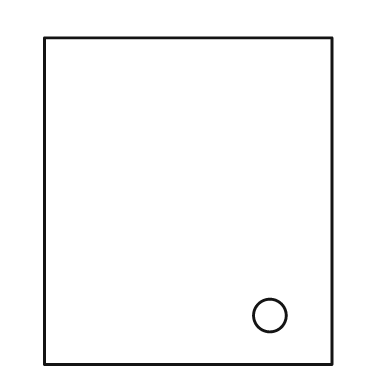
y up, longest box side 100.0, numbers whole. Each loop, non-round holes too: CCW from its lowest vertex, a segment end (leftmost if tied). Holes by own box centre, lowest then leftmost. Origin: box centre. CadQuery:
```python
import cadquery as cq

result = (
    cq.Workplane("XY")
    .moveTo(-44.0, -50.0)
    .lineTo(44.0, -50.0)
    .lineTo(44.0, 50.0)
    .lineTo(-44.0, 50.0)
    .close()
    .moveTo(25.0, -35.0)
    .circle(5.0)
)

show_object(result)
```